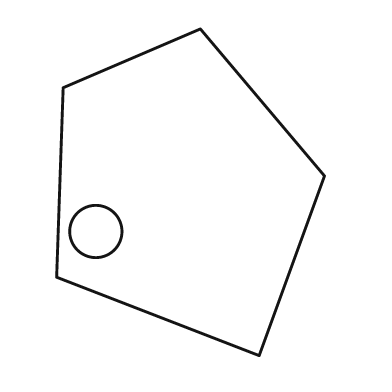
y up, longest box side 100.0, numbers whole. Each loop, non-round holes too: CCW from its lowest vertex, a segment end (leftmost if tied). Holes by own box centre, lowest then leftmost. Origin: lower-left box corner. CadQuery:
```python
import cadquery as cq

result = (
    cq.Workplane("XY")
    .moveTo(62.0, 0.0)
    .lineTo(82.0, 55.0)
    .lineTo(44.0, 100.0)
    .lineTo(2.0, 82.0)
    .lineTo(0.0, 24.0)
    .close()
    .moveTo(12.0, 38.0)
    .circle(8.0)
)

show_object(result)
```